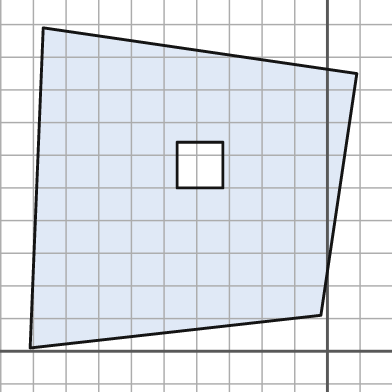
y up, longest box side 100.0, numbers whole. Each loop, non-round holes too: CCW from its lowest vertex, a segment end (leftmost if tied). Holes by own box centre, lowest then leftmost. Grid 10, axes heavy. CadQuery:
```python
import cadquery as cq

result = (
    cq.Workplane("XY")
    .moveTo(-91.0, 1.0)
    .lineTo(-2.0, 11.0)
    .lineTo(9.0, 85.0)
    .lineTo(-87.0, 99.0)
    .close()
    .moveTo(-46.0, 50.0)
    .lineTo(-32.0, 50.0)
    .lineTo(-32.0, 64.0)
    .lineTo(-46.0, 64.0)
    .close()
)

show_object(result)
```